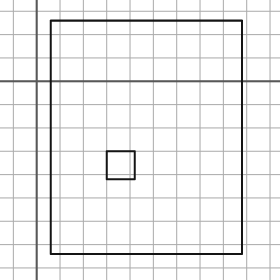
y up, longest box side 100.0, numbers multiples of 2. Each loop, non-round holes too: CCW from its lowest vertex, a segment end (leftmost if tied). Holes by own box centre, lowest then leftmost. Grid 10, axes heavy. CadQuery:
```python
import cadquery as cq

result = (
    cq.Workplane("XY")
    .moveTo(6.0, -74.0)
    .lineTo(88.0, -74.0)
    .lineTo(88.0, 26.0)
    .lineTo(6.0, 26.0)
    .close()
    .moveTo(30.0, -42.0)
    .lineTo(42.0, -42.0)
    .lineTo(42.0, -30.0)
    .lineTo(30.0, -30.0)
    .close()
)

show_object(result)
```